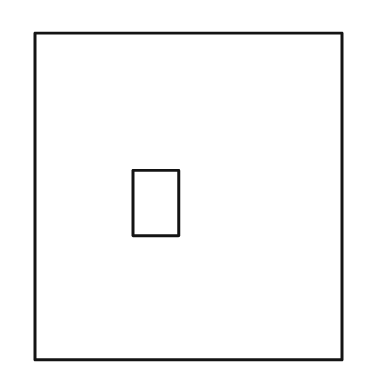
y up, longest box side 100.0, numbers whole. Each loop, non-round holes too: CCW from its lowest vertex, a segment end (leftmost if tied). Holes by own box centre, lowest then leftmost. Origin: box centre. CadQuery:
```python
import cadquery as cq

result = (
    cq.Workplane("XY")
    .moveTo(-47.0, -50.0)
    .lineTo(47.0, -50.0)
    .lineTo(47.0, 50.0)
    .lineTo(-47.0, 50.0)
    .close()
    .moveTo(-17.0, -12.0)
    .lineTo(-3.0, -12.0)
    .lineTo(-3.0, 8.0)
    .lineTo(-17.0, 8.0)
    .close()
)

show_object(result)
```